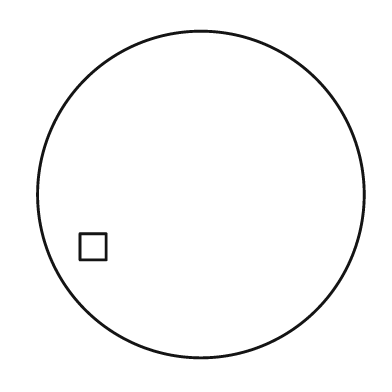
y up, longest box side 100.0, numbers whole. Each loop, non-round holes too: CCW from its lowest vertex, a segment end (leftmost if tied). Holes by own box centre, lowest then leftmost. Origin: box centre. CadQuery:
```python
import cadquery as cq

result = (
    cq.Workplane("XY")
    .moveTo(0.0, 0.0)
    .circle(50.0)
    .moveTo(-37.0, -20.0)
    .lineTo(-29.0, -20.0)
    .lineTo(-29.0, -12.0)
    .lineTo(-37.0, -12.0)
    .close()
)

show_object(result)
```